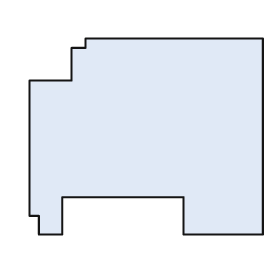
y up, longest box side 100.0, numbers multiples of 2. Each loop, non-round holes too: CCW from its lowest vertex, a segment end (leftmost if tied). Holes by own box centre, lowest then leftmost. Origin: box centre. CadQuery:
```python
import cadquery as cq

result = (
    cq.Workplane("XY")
    .moveTo(-46.0, -42.0)
    .lineTo(-36.0, -42.0)
    .lineTo(-36.0, -26.0)
    .lineTo(16.0, -26.0)
    .lineTo(16.0, -42.0)
    .lineTo(50.0, -42.0)
    .lineTo(50.0, 42.0)
    .lineTo(-26.0, 42.0)
    .lineTo(-26.0, 38.0)
    .lineTo(-32.0, 38.0)
    .lineTo(-32.0, 24.0)
    .lineTo(-50.0, 24.0)
    .lineTo(-50.0, -34.0)
    .lineTo(-46.0, -34.0)
    .close()
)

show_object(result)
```